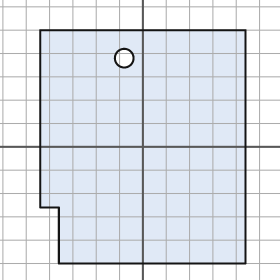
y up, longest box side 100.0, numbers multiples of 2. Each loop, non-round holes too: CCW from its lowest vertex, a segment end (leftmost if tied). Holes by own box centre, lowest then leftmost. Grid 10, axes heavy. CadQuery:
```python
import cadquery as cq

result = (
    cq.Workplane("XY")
    .moveTo(-36.0, -50.0)
    .lineTo(44.0, -50.0)
    .lineTo(44.0, 50.0)
    .lineTo(-44.0, 50.0)
    .lineTo(-44.0, -26.0)
    .lineTo(-36.0, -26.0)
    .close()
    .moveTo(-8.0, 38.0)
    .circle(4.0)
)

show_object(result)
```